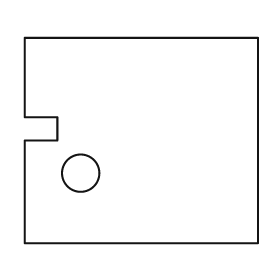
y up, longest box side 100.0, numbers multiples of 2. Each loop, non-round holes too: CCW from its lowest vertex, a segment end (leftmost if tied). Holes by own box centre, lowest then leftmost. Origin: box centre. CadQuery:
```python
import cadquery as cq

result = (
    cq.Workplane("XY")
    .moveTo(-50.0, -44.0)
    .lineTo(50.0, -44.0)
    .lineTo(50.0, 44.0)
    .lineTo(-50.0, 44.0)
    .lineTo(-50.0, 10.0)
    .lineTo(-36.0, 10.0)
    .lineTo(-36.0, 0.0)
    .lineTo(-50.0, 0.0)
    .close()
    .moveTo(-26.0, -14.0)
    .circle(8.0)
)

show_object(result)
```